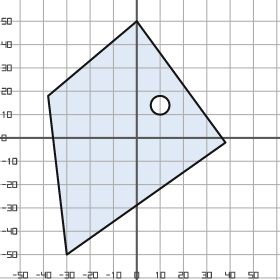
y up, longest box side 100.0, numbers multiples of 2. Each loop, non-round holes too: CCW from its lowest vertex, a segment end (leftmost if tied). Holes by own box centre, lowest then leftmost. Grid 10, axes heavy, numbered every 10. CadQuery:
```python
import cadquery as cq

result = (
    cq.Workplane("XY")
    .moveTo(-30.0, -50.0)
    .lineTo(38.0, -2.0)
    .lineTo(0.0, 50.0)
    .lineTo(-38.0, 18.0)
    .close()
    .moveTo(10.0, 14.0)
    .circle(4.0)
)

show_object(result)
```